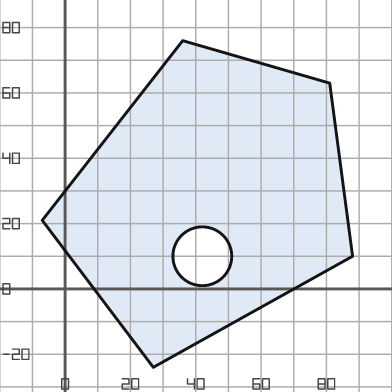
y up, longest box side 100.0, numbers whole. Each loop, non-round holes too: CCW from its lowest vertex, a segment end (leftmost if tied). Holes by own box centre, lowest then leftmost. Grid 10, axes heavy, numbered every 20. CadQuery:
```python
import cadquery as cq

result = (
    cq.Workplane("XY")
    .moveTo(27.0, -24.0)
    .lineTo(88.0, 10.0)
    .lineTo(81.0, 63.0)
    .lineTo(36.0, 76.0)
    .lineTo(-7.0, 21.0)
    .close()
    .moveTo(42.0, 10.0)
    .circle(9.0)
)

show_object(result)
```